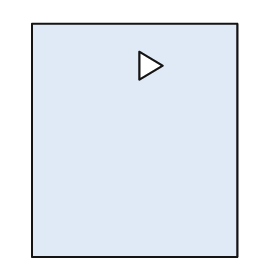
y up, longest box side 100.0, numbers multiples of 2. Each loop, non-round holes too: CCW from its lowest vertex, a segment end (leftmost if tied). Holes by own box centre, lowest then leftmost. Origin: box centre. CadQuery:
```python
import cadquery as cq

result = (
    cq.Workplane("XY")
    .moveTo(-44.0, -50.0)
    .lineTo(44.0, -50.0)
    .lineTo(44.0, 50.0)
    .lineTo(-44.0, 50.0)
    .close()
    .moveTo(2.0, 26.0)
    .lineTo(12.0, 32.0)
    .lineTo(2.0, 38.0)
    .close()
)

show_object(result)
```